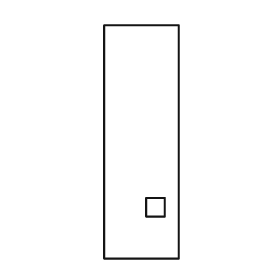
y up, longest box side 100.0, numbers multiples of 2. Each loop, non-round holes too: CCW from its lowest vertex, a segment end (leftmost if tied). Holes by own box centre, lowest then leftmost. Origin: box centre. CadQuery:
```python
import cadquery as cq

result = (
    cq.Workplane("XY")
    .moveTo(-16.0, -50.0)
    .lineTo(16.0, -50.0)
    .lineTo(16.0, 50.0)
    .lineTo(-16.0, 50.0)
    .close()
    .moveTo(2.0, -32.0)
    .lineTo(10.0, -32.0)
    .lineTo(10.0, -24.0)
    .lineTo(2.0, -24.0)
    .close()
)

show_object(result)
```